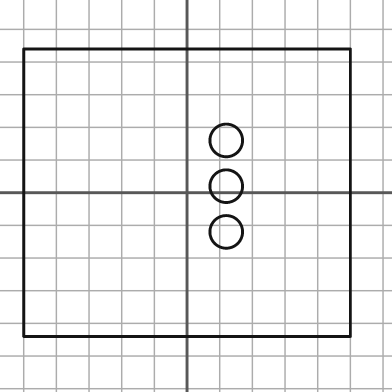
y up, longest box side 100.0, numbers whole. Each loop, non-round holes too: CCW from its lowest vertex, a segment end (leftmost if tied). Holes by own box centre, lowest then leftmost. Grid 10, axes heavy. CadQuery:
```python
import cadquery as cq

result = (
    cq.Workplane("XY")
    .moveTo(-50.0, -44.0)
    .lineTo(50.0, -44.0)
    .lineTo(50.0, 44.0)
    .lineTo(-50.0, 44.0)
    .close()
    .moveTo(12.0, -12.0)
    .circle(5.0)
    .moveTo(12.0, 2.0)
    .circle(5.0)
    .moveTo(12.0, 16.0)
    .circle(5.0)
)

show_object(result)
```